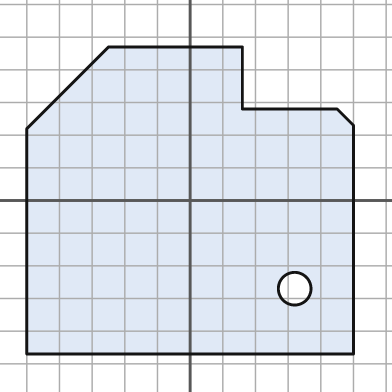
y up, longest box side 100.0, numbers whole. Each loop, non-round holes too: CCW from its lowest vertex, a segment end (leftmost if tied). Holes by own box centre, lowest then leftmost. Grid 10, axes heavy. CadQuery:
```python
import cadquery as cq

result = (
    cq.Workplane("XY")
    .moveTo(-50.0, -47.0)
    .lineTo(50.0, -47.0)
    .lineTo(50.0, 23.0)
    .lineTo(45.0, 28.0)
    .lineTo(16.0, 28.0)
    .lineTo(16.0, 47.0)
    .lineTo(-25.0, 47.0)
    .lineTo(-50.0, 22.0)
    .close()
    .moveTo(32.0, -27.0)
    .circle(5.0)
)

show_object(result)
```